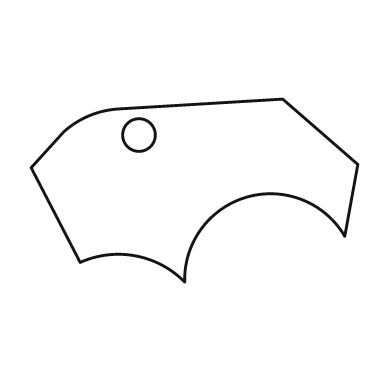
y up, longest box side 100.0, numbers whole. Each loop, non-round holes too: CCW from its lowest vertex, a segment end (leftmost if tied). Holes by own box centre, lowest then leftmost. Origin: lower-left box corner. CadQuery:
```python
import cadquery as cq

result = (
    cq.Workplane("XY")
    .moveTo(47.0, 0.0)
    .threePointArc((66.0, 26.0), (96.0, 14.0))
    .lineTo(100.0, 36.0)
    .lineTo(77.0, 56.0)
    .lineTo(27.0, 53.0)
    .threePointArc((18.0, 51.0), (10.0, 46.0))
    .lineTo(0.0, 35.0)
    .lineTo(15.0, 6.0)
    .threePointArc((32.0, 8.0), (47.0, 0.0))
    .close()
    .moveTo(33.0, 45.0)
    .circle(5.0)
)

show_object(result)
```